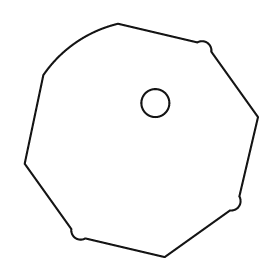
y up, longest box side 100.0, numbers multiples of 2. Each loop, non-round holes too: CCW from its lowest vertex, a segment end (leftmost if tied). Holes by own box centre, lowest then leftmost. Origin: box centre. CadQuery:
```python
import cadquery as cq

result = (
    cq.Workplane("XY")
    .moveTo(10.0, -50.0)
    .lineTo(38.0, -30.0)
    .threePointArc((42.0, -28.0), (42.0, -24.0))
    .lineTo(50.0, 10.0)
    .lineTo(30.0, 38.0)
    .threePointArc((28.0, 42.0), (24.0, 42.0))
    .lineTo(-10.0, 50.0)
    .threePointArc((-28.0, 42.0), (-42.0, 28.0))
    .lineTo(-50.0, -10.0)
    .lineTo(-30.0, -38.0)
    .threePointArc((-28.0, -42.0), (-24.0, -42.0))
    .close()
    .moveTo(6.0, 16.0)
    .circle(6.0)
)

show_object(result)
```